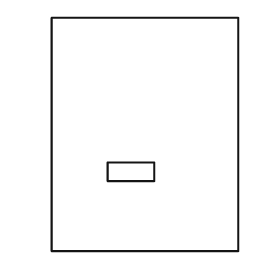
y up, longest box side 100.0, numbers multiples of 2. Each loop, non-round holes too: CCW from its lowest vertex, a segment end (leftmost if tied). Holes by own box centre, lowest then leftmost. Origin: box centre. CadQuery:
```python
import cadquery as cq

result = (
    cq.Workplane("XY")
    .moveTo(-40.0, -50.0)
    .lineTo(40.0, -50.0)
    .lineTo(40.0, 50.0)
    .lineTo(-40.0, 50.0)
    .close()
    .moveTo(-16.0, -20.0)
    .lineTo(4.0, -20.0)
    .lineTo(4.0, -12.0)
    .lineTo(-16.0, -12.0)
    .close()
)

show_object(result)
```